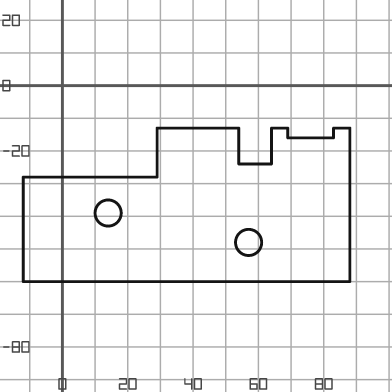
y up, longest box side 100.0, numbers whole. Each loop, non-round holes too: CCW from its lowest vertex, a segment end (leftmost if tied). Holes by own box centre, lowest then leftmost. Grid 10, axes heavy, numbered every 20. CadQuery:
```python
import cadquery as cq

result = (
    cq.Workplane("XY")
    .moveTo(-12.0, -60.0)
    .lineTo(88.0, -60.0)
    .lineTo(88.0, -13.0)
    .lineTo(83.0, -13.0)
    .lineTo(83.0, -16.0)
    .lineTo(69.0, -16.0)
    .lineTo(69.0, -13.0)
    .lineTo(64.0, -13.0)
    .lineTo(64.0, -24.0)
    .lineTo(54.0, -24.0)
    .lineTo(54.0, -13.0)
    .lineTo(29.0, -13.0)
    .lineTo(29.0, -28.0)
    .lineTo(-12.0, -28.0)
    .close()
    .moveTo(57.0, -48.0)
    .circle(4.0)
    .moveTo(14.0, -39.0)
    .circle(4.0)
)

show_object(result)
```